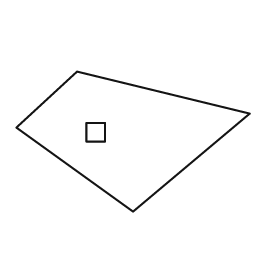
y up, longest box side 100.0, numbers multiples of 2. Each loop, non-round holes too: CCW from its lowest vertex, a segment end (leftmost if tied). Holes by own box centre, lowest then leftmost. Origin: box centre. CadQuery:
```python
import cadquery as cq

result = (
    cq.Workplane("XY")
    .moveTo(0.0, -30.0)
    .lineTo(50.0, 12.0)
    .lineTo(-24.0, 30.0)
    .lineTo(-50.0, 6.0)
    .close()
    .moveTo(-20.0, 0.0)
    .lineTo(-12.0, 0.0)
    .lineTo(-12.0, 8.0)
    .lineTo(-20.0, 8.0)
    .close()
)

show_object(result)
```